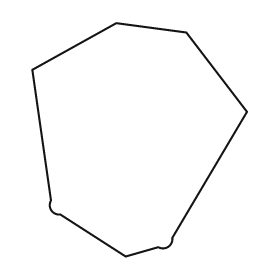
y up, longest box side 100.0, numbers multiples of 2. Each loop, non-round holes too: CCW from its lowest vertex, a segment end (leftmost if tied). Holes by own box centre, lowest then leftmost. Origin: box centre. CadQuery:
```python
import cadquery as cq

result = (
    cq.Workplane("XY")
    .moveTo(-6.0, -50.0)
    .lineTo(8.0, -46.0)
    .threePointArc((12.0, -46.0), (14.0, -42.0))
    .lineTo(46.0, 12.0)
    .lineTo(20.0, 46.0)
    .lineTo(-10.0, 50.0)
    .lineTo(-46.0, 30.0)
    .lineTo(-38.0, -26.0)
    .threePointArc((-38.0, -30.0), (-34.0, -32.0))
    .close()
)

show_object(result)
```